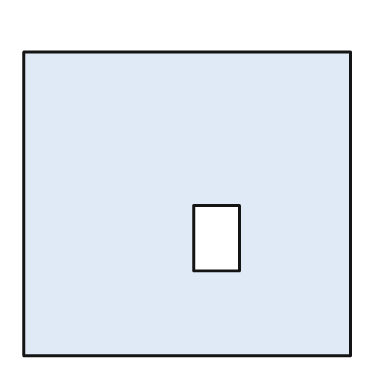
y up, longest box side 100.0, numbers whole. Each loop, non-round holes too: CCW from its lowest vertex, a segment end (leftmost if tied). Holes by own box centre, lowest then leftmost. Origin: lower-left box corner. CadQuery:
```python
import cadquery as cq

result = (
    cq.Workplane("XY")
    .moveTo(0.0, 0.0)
    .lineTo(100.0, 0.0)
    .lineTo(100.0, 93.0)
    .lineTo(0.0, 93.0)
    .close()
    .moveTo(52.0, 26.0)
    .lineTo(66.0, 26.0)
    .lineTo(66.0, 46.0)
    .lineTo(52.0, 46.0)
    .close()
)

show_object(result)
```